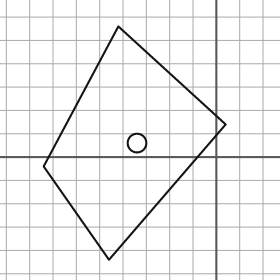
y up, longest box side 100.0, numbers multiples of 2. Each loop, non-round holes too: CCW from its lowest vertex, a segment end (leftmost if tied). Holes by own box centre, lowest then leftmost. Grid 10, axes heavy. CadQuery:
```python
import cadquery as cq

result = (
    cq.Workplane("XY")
    .moveTo(-46.0, -44.0)
    .lineTo(4.0, 14.0)
    .lineTo(-42.0, 56.0)
    .lineTo(-74.0, -4.0)
    .close()
    .moveTo(-34.0, 6.0)
    .circle(4.0)
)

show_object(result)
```